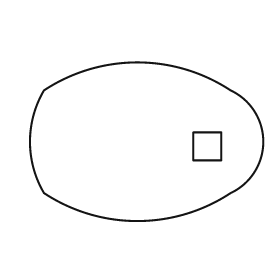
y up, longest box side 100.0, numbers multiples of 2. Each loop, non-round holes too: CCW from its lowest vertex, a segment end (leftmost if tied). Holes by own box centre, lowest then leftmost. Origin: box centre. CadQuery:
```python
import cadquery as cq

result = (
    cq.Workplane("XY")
    .moveTo(-44.0, -22.0)
    .threePointArc((-4.0, -34.0), (36.0, -22.0))
    .threePointArc((50.0, 0.0), (36.0, 22.0))
    .threePointArc((-4.0, 34.0), (-44.0, 22.0))
    .threePointArc((-50.0, 0.0), (-44.0, -22.0))
    .close()
    .moveTo(20.0, -8.0)
    .lineTo(32.0, -8.0)
    .lineTo(32.0, 4.0)
    .lineTo(20.0, 4.0)
    .close()
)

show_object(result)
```